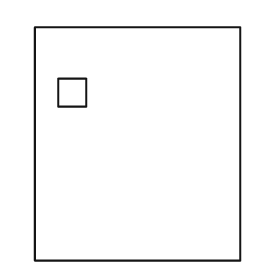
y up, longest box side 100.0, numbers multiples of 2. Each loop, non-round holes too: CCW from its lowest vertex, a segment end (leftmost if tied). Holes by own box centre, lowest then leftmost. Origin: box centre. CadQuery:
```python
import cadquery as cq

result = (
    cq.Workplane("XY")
    .moveTo(-44.0, -50.0)
    .lineTo(44.0, -50.0)
    .lineTo(44.0, 50.0)
    .lineTo(-44.0, 50.0)
    .close()
    .moveTo(-34.0, 16.0)
    .lineTo(-22.0, 16.0)
    .lineTo(-22.0, 28.0)
    .lineTo(-34.0, 28.0)
    .close()
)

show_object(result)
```